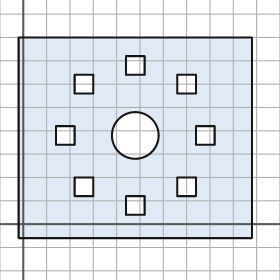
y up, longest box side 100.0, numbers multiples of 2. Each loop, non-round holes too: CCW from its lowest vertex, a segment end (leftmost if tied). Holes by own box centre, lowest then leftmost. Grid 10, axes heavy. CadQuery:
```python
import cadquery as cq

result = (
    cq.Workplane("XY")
    .moveTo(-2.0, -6.0)
    .lineTo(98.0, -6.0)
    .lineTo(98.0, 80.0)
    .lineTo(-2.0, 80.0)
    .close()
    .moveTo(44.0, 4.0)
    .lineTo(52.0, 4.0)
    .lineTo(52.0, 12.0)
    .lineTo(44.0, 12.0)
    .close()
    .moveTo(22.0, 12.0)
    .lineTo(30.0, 12.0)
    .lineTo(30.0, 20.0)
    .lineTo(22.0, 20.0)
    .close()
    .moveTo(66.0, 12.0)
    .lineTo(74.0, 12.0)
    .lineTo(74.0, 20.0)
    .lineTo(66.0, 20.0)
    .close()
    .moveTo(14.0, 34.0)
    .lineTo(22.0, 34.0)
    .lineTo(22.0, 42.0)
    .lineTo(14.0, 42.0)
    .close()
    .moveTo(48.0, 38.0)
    .circle(10.0)
    .moveTo(74.0, 34.0)
    .lineTo(82.0, 34.0)
    .lineTo(82.0, 42.0)
    .lineTo(74.0, 42.0)
    .close()
    .moveTo(22.0, 56.0)
    .lineTo(30.0, 56.0)
    .lineTo(30.0, 64.0)
    .lineTo(22.0, 64.0)
    .close()
    .moveTo(66.0, 56.0)
    .lineTo(74.0, 56.0)
    .lineTo(74.0, 64.0)
    .lineTo(66.0, 64.0)
    .close()
    .moveTo(44.0, 64.0)
    .lineTo(52.0, 64.0)
    .lineTo(52.0, 72.0)
    .lineTo(44.0, 72.0)
    .close()
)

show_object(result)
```